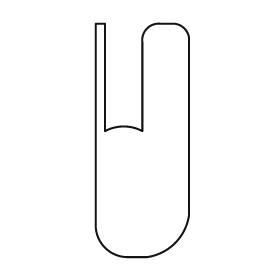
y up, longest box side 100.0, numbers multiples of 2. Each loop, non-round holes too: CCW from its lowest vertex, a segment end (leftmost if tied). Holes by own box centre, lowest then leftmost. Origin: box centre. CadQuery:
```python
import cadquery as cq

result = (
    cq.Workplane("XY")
    .moveTo(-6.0, -50.0)
    .lineTo(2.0, -50.0)
    .threePointArc((14.0, -44.0), (20.0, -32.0))
    .lineTo(20.0, 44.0)
    .threePointArc((18.0, 48.0), (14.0, 50.0))
    .lineTo(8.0, 50.0)
    .threePointArc((2.0, 48.0), (0.0, 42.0))
    .lineTo(0.0, 4.0)
    .threePointArc((-8.0, 6.0), (-16.0, 4.0))
    .lineTo(-16.0, 50.0)
    .lineTo(-20.0, 50.0)
    .lineTo(-20.0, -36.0)
    .threePointArc((-16.0, -46.0), (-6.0, -50.0))
    .close()
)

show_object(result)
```